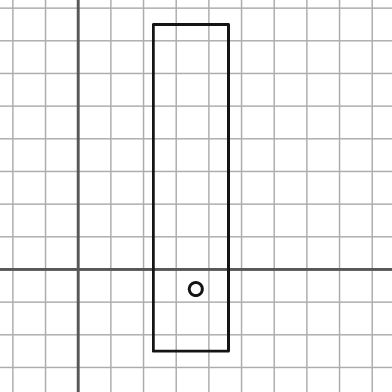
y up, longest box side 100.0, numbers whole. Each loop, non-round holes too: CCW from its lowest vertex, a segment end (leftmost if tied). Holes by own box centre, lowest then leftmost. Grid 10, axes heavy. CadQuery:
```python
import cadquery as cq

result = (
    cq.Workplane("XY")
    .moveTo(23.0, -25.0)
    .lineTo(46.0, -25.0)
    .lineTo(46.0, 75.0)
    .lineTo(23.0, 75.0)
    .close()
    .moveTo(36.0, -6.0)
    .circle(2.0)
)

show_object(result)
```